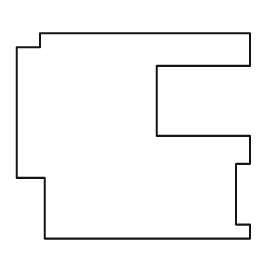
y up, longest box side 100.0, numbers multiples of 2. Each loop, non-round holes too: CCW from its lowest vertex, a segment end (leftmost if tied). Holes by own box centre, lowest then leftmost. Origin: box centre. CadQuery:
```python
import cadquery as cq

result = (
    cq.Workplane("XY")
    .moveTo(-38.0, -44.0)
    .lineTo(50.0, -44.0)
    .lineTo(50.0, -38.0)
    .lineTo(44.0, -38.0)
    .lineTo(44.0, -12.0)
    .lineTo(50.0, -12.0)
    .lineTo(50.0, 0.0)
    .lineTo(10.0, 0.0)
    .lineTo(10.0, 30.0)
    .lineTo(50.0, 30.0)
    .lineTo(50.0, 44.0)
    .lineTo(-40.0, 44.0)
    .lineTo(-40.0, 38.0)
    .lineTo(-50.0, 38.0)
    .lineTo(-50.0, -18.0)
    .lineTo(-38.0, -18.0)
    .close()
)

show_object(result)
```